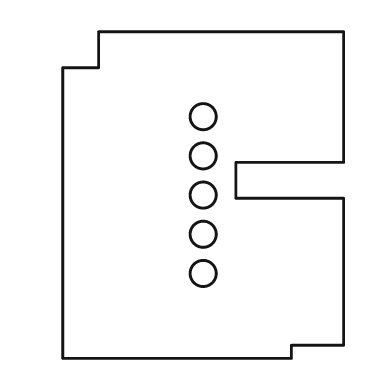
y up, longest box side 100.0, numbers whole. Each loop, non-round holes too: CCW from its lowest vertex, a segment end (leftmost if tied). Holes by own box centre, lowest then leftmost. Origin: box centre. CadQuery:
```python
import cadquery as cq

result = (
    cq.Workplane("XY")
    .moveTo(-43.0, -50.0)
    .lineTo(27.0, -50.0)
    .lineTo(27.0, -46.0)
    .lineTo(43.0, -46.0)
    .lineTo(43.0, -1.0)
    .lineTo(10.0, -1.0)
    .lineTo(10.0, 10.0)
    .lineTo(43.0, 10.0)
    .lineTo(43.0, 50.0)
    .lineTo(-32.0, 50.0)
    .lineTo(-32.0, 39.0)
    .lineTo(-43.0, 39.0)
    .close()
    .moveTo(0.0, -24.0)
    .circle(4.0)
    .moveTo(0.0, -12.0)
    .circle(4.0)
    .moveTo(0.0, 0.0)
    .circle(4.0)
    .moveTo(0.0, 12.0)
    .circle(4.0)
    .moveTo(0.0, 24.0)
    .circle(4.0)
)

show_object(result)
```